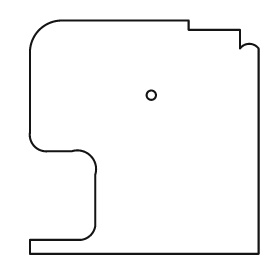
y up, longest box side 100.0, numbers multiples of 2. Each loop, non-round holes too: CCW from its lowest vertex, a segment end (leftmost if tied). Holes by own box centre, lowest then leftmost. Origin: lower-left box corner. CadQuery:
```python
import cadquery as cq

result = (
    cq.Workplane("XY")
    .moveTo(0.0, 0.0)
    .lineTo(98.0, 0.0)
    .lineTo(98.0, 88.0)
    .threePointArc((94.0, 90.0), (90.0, 88.0))
    .lineTo(90.0, 96.0)
    .lineTo(68.0, 96.0)
    .lineTo(68.0, 100.0)
    .lineTo(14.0, 100.0)
    .threePointArc((4.0, 96.0), (0.0, 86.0))
    .lineTo(0.0, 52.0)
    .threePointArc((2.0, 46.0), (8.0, 44.0))
    .lineTo(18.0, 44.0)
    .threePointArc((26.0, 42.0), (28.0, 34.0))
    .lineTo(28.0, 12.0)
    .threePointArc((26.0, 8.0), (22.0, 6.0))
    .lineTo(0.0, 6.0)
    .close()
    .moveTo(52.0, 68.0)
    .circle(2.0)
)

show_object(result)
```